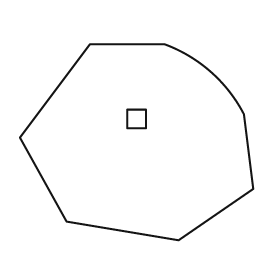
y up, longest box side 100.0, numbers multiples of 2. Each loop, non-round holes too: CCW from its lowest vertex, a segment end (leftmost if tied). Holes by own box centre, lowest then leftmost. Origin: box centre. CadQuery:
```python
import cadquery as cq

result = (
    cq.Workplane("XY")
    .moveTo(18.0, -42.0)
    .lineTo(50.0, -20.0)
    .lineTo(46.0, 12.0)
    .threePointArc((32.0, 30.0), (12.0, 42.0))
    .lineTo(-20.0, 42.0)
    .lineTo(-50.0, 2.0)
    .lineTo(-30.0, -34.0)
    .close()
    .moveTo(-4.0, 6.0)
    .lineTo(4.0, 6.0)
    .lineTo(4.0, 14.0)
    .lineTo(-4.0, 14.0)
    .close()
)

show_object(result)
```